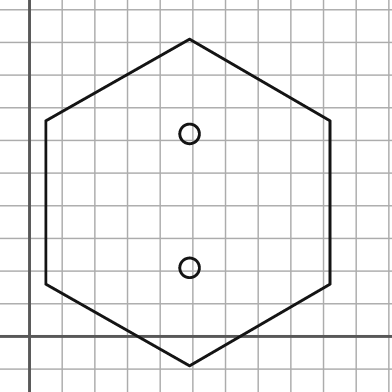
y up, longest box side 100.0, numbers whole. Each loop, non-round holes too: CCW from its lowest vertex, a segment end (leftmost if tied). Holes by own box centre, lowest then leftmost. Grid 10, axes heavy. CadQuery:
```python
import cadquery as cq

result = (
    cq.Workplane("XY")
    .moveTo(49.0, -9.0)
    .lineTo(92.0, 16.0)
    .lineTo(92.0, 66.0)
    .lineTo(49.0, 91.0)
    .lineTo(5.0, 66.0)
    .lineTo(5.0, 16.0)
    .close()
    .moveTo(49.0, 21.0)
    .circle(3.0)
    .moveTo(49.0, 62.0)
    .circle(3.0)
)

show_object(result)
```